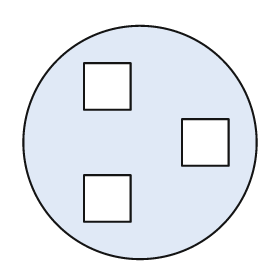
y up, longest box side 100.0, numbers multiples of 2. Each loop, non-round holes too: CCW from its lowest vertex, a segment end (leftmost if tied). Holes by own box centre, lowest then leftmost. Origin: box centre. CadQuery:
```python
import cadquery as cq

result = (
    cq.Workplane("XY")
    .moveTo(0.0, 0.0)
    .circle(50.0)
    .moveTo(-24.0, -34.0)
    .lineTo(-4.0, -34.0)
    .lineTo(-4.0, -14.0)
    .lineTo(-24.0, -14.0)
    .close()
    .moveTo(18.0, -10.0)
    .lineTo(38.0, -10.0)
    .lineTo(38.0, 10.0)
    .lineTo(18.0, 10.0)
    .close()
    .moveTo(-24.0, 14.0)
    .lineTo(-4.0, 14.0)
    .lineTo(-4.0, 34.0)
    .lineTo(-24.0, 34.0)
    .close()
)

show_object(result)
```